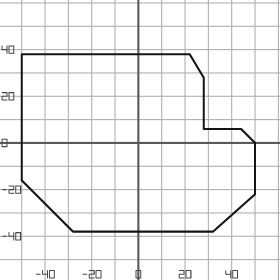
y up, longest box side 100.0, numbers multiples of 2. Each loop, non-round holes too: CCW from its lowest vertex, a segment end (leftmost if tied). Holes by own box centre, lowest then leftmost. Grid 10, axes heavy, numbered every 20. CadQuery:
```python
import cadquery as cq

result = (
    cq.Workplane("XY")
    .moveTo(-28.0, -38.0)
    .lineTo(32.0, -38.0)
    .lineTo(50.0, -22.0)
    .lineTo(50.0, 0.0)
    .lineTo(44.0, 6.0)
    .lineTo(28.0, 6.0)
    .lineTo(28.0, 28.0)
    .lineTo(22.0, 38.0)
    .lineTo(-50.0, 38.0)
    .lineTo(-50.0, -16.0)
    .close()
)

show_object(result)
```